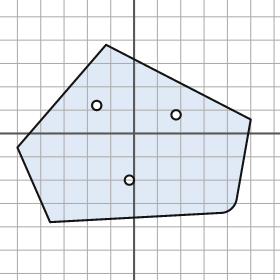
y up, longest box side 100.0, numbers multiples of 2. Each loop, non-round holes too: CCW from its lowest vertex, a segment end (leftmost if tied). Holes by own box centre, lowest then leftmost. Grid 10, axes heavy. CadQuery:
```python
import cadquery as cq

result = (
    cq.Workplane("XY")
    .moveTo(-36.0, -38.0)
    .lineTo(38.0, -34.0)
    .threePointArc((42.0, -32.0), (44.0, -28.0))
    .lineTo(50.0, 6.0)
    .lineTo(-12.0, 38.0)
    .lineTo(-50.0, -6.0)
    .close()
    .moveTo(-2.0, -20.0)
    .circle(2.0)
    .moveTo(18.0, 8.0)
    .circle(2.0)
    .moveTo(-16.0, 12.0)
    .circle(2.0)
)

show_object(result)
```